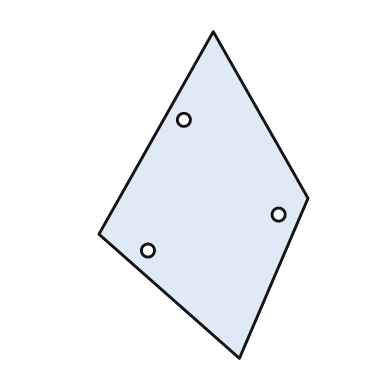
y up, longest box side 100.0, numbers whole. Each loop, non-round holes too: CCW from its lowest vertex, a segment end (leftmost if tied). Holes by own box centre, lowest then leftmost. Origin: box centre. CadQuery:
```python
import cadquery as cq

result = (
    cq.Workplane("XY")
    .moveTo(11.0, -50.0)
    .lineTo(32.0, -1.0)
    .lineTo(3.0, 50.0)
    .lineTo(-32.0, -12.0)
    .close()
    .moveTo(-17.0, -17.0)
    .circle(2.0)
    .moveTo(23.0, -6.0)
    .circle(2.0)
    .moveTo(-6.0, 23.0)
    .circle(2.0)
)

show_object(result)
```